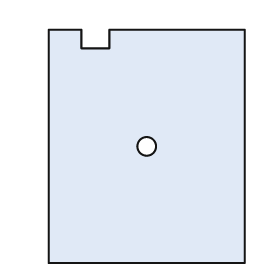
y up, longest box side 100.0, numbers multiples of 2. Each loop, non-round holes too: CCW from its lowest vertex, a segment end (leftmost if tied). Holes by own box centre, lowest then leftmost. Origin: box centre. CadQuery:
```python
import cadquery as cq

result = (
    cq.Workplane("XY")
    .moveTo(-42.0, -50.0)
    .lineTo(42.0, -50.0)
    .lineTo(42.0, 50.0)
    .lineTo(-16.0, 50.0)
    .lineTo(-16.0, 42.0)
    .lineTo(-28.0, 42.0)
    .lineTo(-28.0, 50.0)
    .lineTo(-42.0, 50.0)
    .close()
    .moveTo(0.0, 0.0)
    .circle(4.0)
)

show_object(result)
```